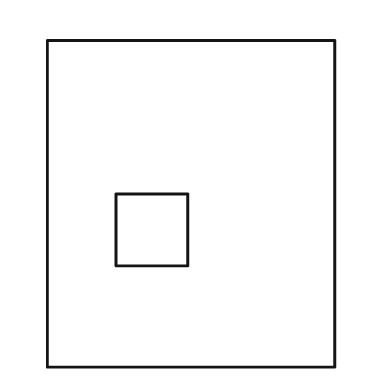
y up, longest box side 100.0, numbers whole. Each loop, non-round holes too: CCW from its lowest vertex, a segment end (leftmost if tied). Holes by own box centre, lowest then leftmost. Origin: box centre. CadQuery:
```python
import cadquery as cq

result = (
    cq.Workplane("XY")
    .moveTo(-44.0, -50.0)
    .lineTo(44.0, -50.0)
    .lineTo(44.0, 50.0)
    .lineTo(-44.0, 50.0)
    .close()
    .moveTo(-23.0, -19.0)
    .lineTo(-1.0, -19.0)
    .lineTo(-1.0, 3.0)
    .lineTo(-23.0, 3.0)
    .close()
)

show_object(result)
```